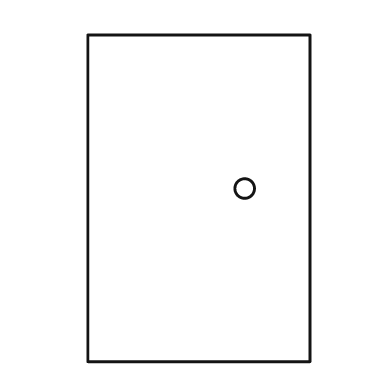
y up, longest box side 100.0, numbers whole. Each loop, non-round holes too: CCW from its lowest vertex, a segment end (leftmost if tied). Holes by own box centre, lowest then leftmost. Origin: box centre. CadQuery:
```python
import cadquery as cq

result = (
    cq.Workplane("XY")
    .moveTo(-34.0, -50.0)
    .lineTo(34.0, -50.0)
    .lineTo(34.0, 50.0)
    .lineTo(-34.0, 50.0)
    .close()
    .moveTo(14.0, 3.0)
    .circle(3.0)
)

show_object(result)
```